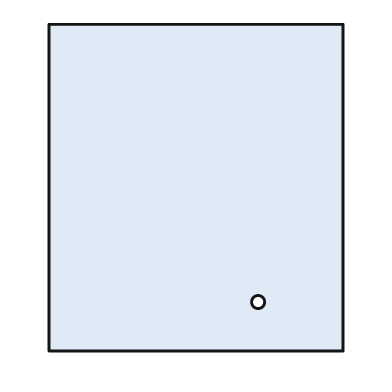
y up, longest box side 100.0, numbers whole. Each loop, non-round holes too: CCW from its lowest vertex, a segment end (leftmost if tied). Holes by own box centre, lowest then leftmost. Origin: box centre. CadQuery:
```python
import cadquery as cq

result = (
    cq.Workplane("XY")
    .moveTo(-45.0, -50.0)
    .lineTo(45.0, -50.0)
    .lineTo(45.0, 50.0)
    .lineTo(-45.0, 50.0)
    .close()
    .moveTo(19.0, -35.0)
    .circle(2.0)
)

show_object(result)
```